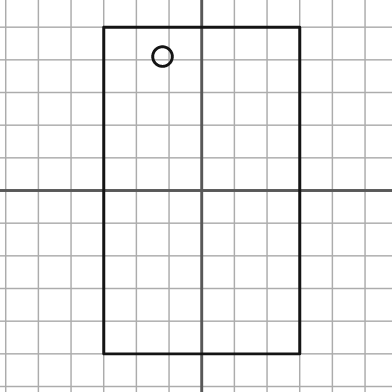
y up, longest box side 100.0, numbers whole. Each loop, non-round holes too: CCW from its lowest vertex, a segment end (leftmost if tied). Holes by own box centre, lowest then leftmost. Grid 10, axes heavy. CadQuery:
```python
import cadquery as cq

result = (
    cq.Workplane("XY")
    .moveTo(-30.0, -50.0)
    .lineTo(30.0, -50.0)
    .lineTo(30.0, 50.0)
    .lineTo(-30.0, 50.0)
    .close()
    .moveTo(-12.0, 41.0)
    .circle(3.0)
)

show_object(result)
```